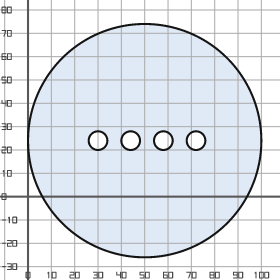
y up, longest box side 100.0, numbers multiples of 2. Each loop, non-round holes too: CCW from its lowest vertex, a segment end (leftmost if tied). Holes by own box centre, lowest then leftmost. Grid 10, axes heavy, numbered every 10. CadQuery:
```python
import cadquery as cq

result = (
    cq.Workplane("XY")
    .moveTo(50.0, 24.0)
    .circle(50.0)
    .moveTo(30.0, 24.0)
    .circle(4.0)
    .moveTo(44.0, 24.0)
    .circle(4.0)
    .moveTo(58.0, 24.0)
    .circle(4.0)
    .moveTo(72.0, 24.0)
    .circle(4.0)
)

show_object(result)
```